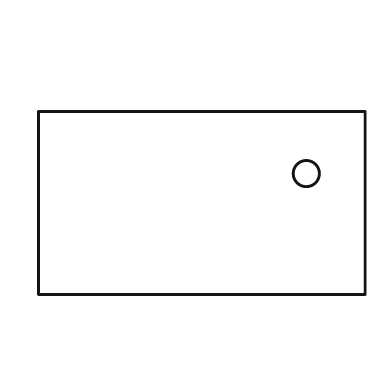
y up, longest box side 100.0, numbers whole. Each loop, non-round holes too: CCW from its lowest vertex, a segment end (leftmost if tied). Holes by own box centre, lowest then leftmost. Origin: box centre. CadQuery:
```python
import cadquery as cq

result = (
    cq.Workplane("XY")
    .moveTo(-50.0, -28.0)
    .lineTo(50.0, -28.0)
    .lineTo(50.0, 28.0)
    .lineTo(-50.0, 28.0)
    .close()
    .moveTo(32.0, 9.0)
    .circle(4.0)
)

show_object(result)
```